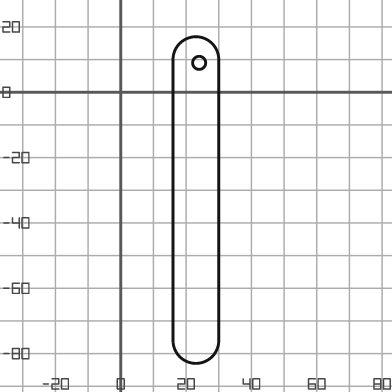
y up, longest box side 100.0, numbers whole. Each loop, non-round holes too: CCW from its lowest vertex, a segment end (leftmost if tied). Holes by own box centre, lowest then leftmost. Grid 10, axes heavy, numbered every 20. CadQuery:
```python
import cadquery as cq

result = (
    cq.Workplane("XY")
    .moveTo(16.0, -76.0)
    .threePointArc((23.0, -83.0), (30.0, -76.0))
    .lineTo(30.0, 10.0)
    .threePointArc((23.0, 17.0), (16.0, 10.0))
    .close()
    .moveTo(24.0, 9.0)
    .circle(2.0)
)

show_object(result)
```